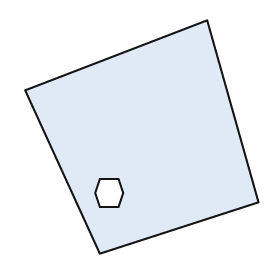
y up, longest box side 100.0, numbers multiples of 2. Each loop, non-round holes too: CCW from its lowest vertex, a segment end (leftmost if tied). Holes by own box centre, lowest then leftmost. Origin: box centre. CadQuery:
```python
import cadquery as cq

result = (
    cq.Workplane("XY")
    .moveTo(-18.0, -50.0)
    .lineTo(50.0, -28.0)
    .lineTo(28.0, 50.0)
    .lineTo(-50.0, 20.0)
    .close()
    .moveTo(-18.0, -30.0)
    .lineTo(-10.0, -30.0)
    .lineTo(-8.0, -24.0)
    .lineTo(-10.0, -18.0)
    .lineTo(-18.0, -18.0)
    .lineTo(-20.0, -24.0)
    .close()
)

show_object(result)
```